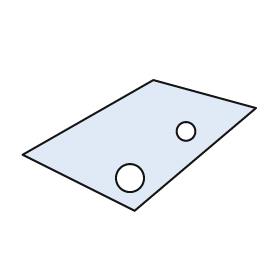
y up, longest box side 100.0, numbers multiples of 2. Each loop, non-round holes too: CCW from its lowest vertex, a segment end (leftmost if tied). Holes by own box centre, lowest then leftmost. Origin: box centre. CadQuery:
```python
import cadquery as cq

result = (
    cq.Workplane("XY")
    .moveTo(-2.0, -28.0)
    .lineTo(50.0, 16.0)
    .lineTo(6.0, 28.0)
    .lineTo(-50.0, -4.0)
    .close()
    .moveTo(-4.0, -14.0)
    .circle(6.0)
    .moveTo(20.0, 6.0)
    .circle(4.0)
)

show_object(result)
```